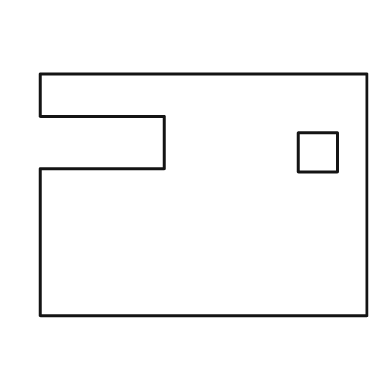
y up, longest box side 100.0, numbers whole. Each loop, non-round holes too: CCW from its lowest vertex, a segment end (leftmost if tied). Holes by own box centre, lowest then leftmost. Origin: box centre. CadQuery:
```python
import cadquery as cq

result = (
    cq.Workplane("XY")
    .moveTo(-50.0, -37.0)
    .lineTo(50.0, -37.0)
    .lineTo(50.0, 37.0)
    .lineTo(-50.0, 37.0)
    .lineTo(-50.0, 24.0)
    .lineTo(-12.0, 24.0)
    .lineTo(-12.0, 8.0)
    .lineTo(-50.0, 8.0)
    .close()
    .moveTo(29.0, 7.0)
    .lineTo(41.0, 7.0)
    .lineTo(41.0, 19.0)
    .lineTo(29.0, 19.0)
    .close()
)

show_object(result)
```